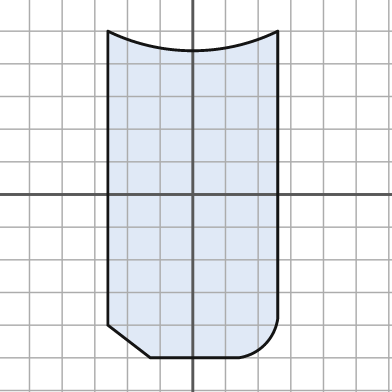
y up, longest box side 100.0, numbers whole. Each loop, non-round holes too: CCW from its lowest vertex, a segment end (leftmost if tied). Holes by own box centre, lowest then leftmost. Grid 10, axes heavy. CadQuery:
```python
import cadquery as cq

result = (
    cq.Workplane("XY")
    .moveTo(-13.0, -50.0)
    .lineTo(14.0, -50.0)
    .threePointArc((22.0, -46.0), (26.0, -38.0))
    .lineTo(26.0, 50.0)
    .threePointArc((0.0, 44.0), (-26.0, 50.0))
    .lineTo(-26.0, -40.0)
    .close()
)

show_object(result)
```